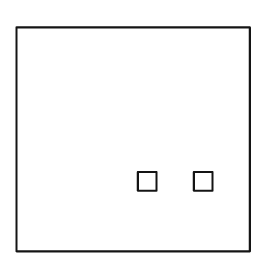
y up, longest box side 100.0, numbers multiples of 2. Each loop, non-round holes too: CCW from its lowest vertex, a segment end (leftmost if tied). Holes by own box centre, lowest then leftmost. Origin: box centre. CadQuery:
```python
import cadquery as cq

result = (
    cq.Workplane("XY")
    .moveTo(-50.0, -48.0)
    .lineTo(50.0, -48.0)
    .lineTo(50.0, 48.0)
    .lineTo(-50.0, 48.0)
    .close()
    .moveTo(2.0, -22.0)
    .lineTo(10.0, -22.0)
    .lineTo(10.0, -14.0)
    .lineTo(2.0, -14.0)
    .close()
    .moveTo(26.0, -22.0)
    .lineTo(34.0, -22.0)
    .lineTo(34.0, -14.0)
    .lineTo(26.0, -14.0)
    .close()
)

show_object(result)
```